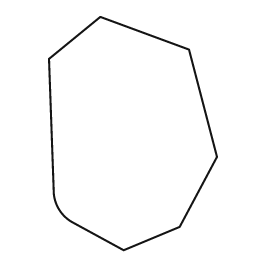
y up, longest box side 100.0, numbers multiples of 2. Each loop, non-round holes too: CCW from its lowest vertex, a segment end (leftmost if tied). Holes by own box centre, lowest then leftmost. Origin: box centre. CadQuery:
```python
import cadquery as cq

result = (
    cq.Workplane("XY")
    .moveTo(-4.0, -50.0)
    .lineTo(20.0, -40.0)
    .lineTo(36.0, -10.0)
    .lineTo(24.0, 36.0)
    .lineTo(-14.0, 50.0)
    .lineTo(-36.0, 32.0)
    .lineTo(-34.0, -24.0)
    .threePointArc((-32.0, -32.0), (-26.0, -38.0))
    .close()
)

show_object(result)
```